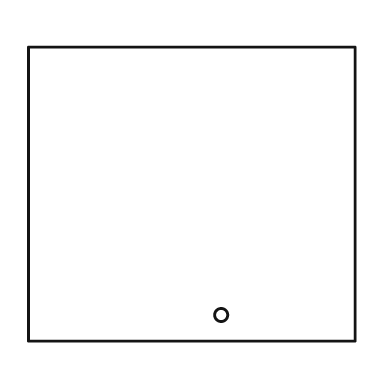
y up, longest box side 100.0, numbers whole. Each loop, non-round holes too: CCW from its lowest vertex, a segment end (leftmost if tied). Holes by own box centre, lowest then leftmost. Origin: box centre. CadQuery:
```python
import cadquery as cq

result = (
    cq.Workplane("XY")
    .moveTo(-50.0, -45.0)
    .lineTo(50.0, -45.0)
    .lineTo(50.0, 45.0)
    .lineTo(-50.0, 45.0)
    .close()
    .moveTo(9.0, -37.0)
    .circle(2.0)
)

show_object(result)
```